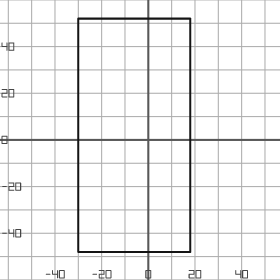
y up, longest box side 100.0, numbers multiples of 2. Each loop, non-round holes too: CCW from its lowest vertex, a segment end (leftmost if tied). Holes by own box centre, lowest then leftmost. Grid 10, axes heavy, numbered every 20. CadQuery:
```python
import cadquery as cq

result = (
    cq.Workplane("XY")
    .moveTo(-30.0, -48.0)
    .lineTo(18.0, -48.0)
    .lineTo(18.0, 52.0)
    .lineTo(-30.0, 52.0)
    .close()
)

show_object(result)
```